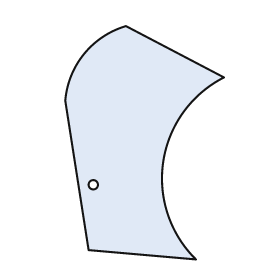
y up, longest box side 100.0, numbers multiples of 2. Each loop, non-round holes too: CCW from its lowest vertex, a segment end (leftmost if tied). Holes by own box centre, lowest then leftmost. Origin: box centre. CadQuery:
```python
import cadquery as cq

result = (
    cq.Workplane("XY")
    .moveTo(22.0, -50.0)
    .threePointArc((8.0, -8.0), (34.0, 28.0))
    .lineTo(-8.0, 50.0)
    .threePointArc((-26.0, 38.0), (-34.0, 18.0))
    .lineTo(-24.0, -46.0)
    .close()
    .moveTo(-22.0, -18.0)
    .circle(2.0)
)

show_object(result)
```